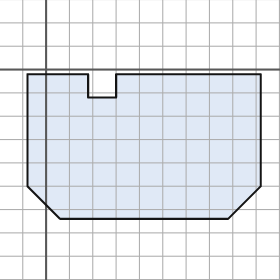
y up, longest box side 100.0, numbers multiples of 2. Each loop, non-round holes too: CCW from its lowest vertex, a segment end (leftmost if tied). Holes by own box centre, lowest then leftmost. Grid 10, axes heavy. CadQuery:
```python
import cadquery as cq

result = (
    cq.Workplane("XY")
    .moveTo(6.0, -64.0)
    .lineTo(78.0, -64.0)
    .lineTo(92.0, -50.0)
    .lineTo(92.0, -2.0)
    .lineTo(30.0, -2.0)
    .lineTo(30.0, -12.0)
    .lineTo(18.0, -12.0)
    .lineTo(18.0, -2.0)
    .lineTo(-8.0, -2.0)
    .lineTo(-8.0, -50.0)
    .close()
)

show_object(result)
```